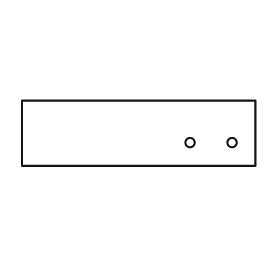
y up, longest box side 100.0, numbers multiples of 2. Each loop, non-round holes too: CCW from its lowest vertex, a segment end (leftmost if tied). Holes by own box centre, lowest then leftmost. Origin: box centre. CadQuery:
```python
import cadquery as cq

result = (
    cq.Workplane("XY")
    .moveTo(-50.0, -14.0)
    .lineTo(50.0, -14.0)
    .lineTo(50.0, 14.0)
    .lineTo(-50.0, 14.0)
    .close()
    .moveTo(22.0, -4.0)
    .circle(2.0)
    .moveTo(40.0, -4.0)
    .circle(2.0)
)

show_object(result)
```